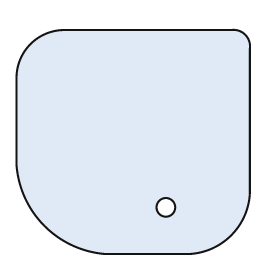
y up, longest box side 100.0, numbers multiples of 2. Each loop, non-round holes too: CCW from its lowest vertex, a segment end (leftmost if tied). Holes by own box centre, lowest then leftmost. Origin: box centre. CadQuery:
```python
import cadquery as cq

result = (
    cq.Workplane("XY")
    .moveTo(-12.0, -48.0)
    .lineTo(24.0, -48.0)
    .threePointArc((42.0, -40.0), (50.0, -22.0))
    .lineTo(50.0, 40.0)
    .threePointArc((48.0, 46.0), (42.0, 48.0))
    .lineTo(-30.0, 48.0)
    .threePointArc((-44.0, 42.0), (-50.0, 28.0))
    .lineTo(-50.0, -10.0)
    .threePointArc((-38.0, -36.0), (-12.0, -48.0))
    .close()
    .moveTo(14.0, -28.0)
    .circle(4.0)
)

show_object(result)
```